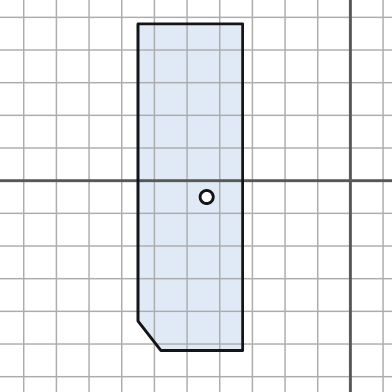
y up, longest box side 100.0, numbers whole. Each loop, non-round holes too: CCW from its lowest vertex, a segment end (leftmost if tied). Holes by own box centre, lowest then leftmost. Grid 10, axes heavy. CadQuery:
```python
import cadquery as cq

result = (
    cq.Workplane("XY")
    .moveTo(-58.0, -52.0)
    .lineTo(-33.0, -52.0)
    .lineTo(-33.0, 48.0)
    .lineTo(-65.0, 48.0)
    .lineTo(-65.0, -43.0)
    .close()
    .moveTo(-44.0, -5.0)
    .circle(2.0)
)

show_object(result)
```